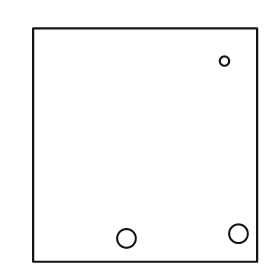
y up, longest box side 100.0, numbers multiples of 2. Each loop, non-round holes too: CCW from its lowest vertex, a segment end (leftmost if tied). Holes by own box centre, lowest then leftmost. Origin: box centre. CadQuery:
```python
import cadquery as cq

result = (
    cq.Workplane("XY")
    .moveTo(-48.0, -50.0)
    .lineTo(48.0, -50.0)
    .lineTo(48.0, 50.0)
    .lineTo(-48.0, 50.0)
    .close()
    .moveTo(-8.0, -40.0)
    .circle(4.0)
    .moveTo(40.0, -38.0)
    .circle(4.0)
    .moveTo(34.0, 36.0)
    .circle(2.0)
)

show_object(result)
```